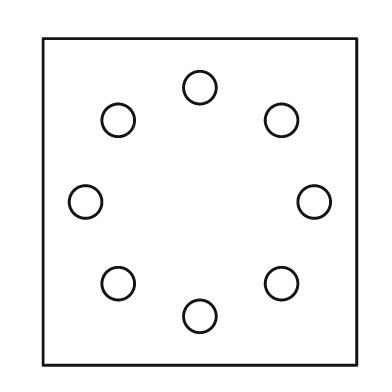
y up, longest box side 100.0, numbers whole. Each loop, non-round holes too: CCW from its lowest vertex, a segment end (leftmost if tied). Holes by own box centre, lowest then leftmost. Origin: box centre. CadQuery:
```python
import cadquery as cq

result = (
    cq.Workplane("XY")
    .moveTo(-48.0, -50.0)
    .lineTo(48.0, -50.0)
    .lineTo(48.0, 50.0)
    .lineTo(-48.0, 50.0)
    .close()
    .moveTo(0.0, -35.0)
    .circle(5.0)
    .moveTo(-25.0, -25.0)
    .circle(5.0)
    .moveTo(25.0, -25.0)
    .circle(5.0)
    .moveTo(-35.0, 0.0)
    .circle(5.0)
    .moveTo(35.0, 0.0)
    .circle(5.0)
    .moveTo(-25.0, 25.0)
    .circle(5.0)
    .moveTo(25.0, 25.0)
    .circle(5.0)
    .moveTo(0.0, 35.0)
    .circle(5.0)
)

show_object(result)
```